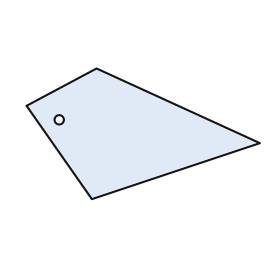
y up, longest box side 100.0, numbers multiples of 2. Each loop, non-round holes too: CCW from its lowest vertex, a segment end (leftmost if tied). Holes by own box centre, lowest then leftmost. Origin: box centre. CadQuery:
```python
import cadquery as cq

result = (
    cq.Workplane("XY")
    .moveTo(-22.0, -28.0)
    .lineTo(50.0, -4.0)
    .lineTo(-20.0, 28.0)
    .lineTo(-50.0, 12.0)
    .close()
    .moveTo(-36.0, 6.0)
    .circle(2.0)
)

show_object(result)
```